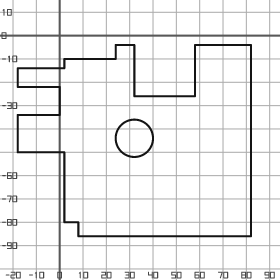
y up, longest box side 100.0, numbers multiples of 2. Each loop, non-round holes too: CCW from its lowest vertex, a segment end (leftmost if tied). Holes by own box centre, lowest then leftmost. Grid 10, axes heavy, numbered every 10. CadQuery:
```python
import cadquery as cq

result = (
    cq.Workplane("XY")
    .moveTo(8.0, -86.0)
    .lineTo(82.0, -86.0)
    .lineTo(82.0, -4.0)
    .lineTo(58.0, -4.0)
    .lineTo(58.0, -26.0)
    .lineTo(32.0, -26.0)
    .lineTo(32.0, -4.0)
    .lineTo(24.0, -4.0)
    .lineTo(24.0, -10.0)
    .lineTo(2.0, -10.0)
    .lineTo(2.0, -14.0)
    .lineTo(-18.0, -14.0)
    .lineTo(-18.0, -22.0)
    .lineTo(0.0, -22.0)
    .lineTo(0.0, -34.0)
    .lineTo(-18.0, -34.0)
    .lineTo(-18.0, -50.0)
    .lineTo(2.0, -50.0)
    .lineTo(2.0, -80.0)
    .lineTo(8.0, -80.0)
    .close()
    .moveTo(32.0, -44.0)
    .circle(8.0)
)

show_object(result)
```